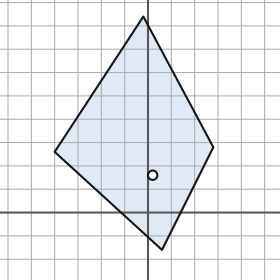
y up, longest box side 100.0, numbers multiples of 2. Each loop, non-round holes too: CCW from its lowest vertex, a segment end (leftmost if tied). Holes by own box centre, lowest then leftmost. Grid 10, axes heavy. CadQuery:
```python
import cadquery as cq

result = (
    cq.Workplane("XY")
    .moveTo(6.0, -16.0)
    .lineTo(28.0, 28.0)
    .lineTo(-2.0, 84.0)
    .lineTo(-40.0, 26.0)
    .close()
    .moveTo(2.0, 16.0)
    .circle(2.0)
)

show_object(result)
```